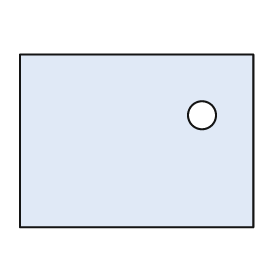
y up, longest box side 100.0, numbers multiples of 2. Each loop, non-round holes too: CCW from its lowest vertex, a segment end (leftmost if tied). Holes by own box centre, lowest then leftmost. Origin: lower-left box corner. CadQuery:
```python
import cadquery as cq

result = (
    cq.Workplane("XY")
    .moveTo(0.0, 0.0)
    .lineTo(100.0, 0.0)
    .lineTo(100.0, 74.0)
    .lineTo(0.0, 74.0)
    .close()
    .moveTo(78.0, 48.0)
    .circle(6.0)
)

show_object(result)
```